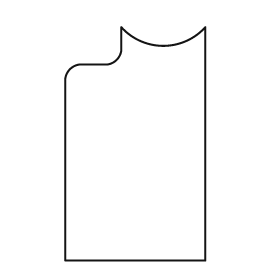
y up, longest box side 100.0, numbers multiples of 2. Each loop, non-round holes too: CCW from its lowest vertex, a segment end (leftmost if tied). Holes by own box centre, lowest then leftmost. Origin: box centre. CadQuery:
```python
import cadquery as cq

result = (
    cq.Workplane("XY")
    .moveTo(-30.0, -50.0)
    .lineTo(30.0, -50.0)
    .lineTo(30.0, 50.0)
    .threePointArc((12.0, 42.0), (-6.0, 50.0))
    .lineTo(-6.0, 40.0)
    .threePointArc((-8.0, 36.0), (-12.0, 34.0))
    .lineTo(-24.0, 34.0)
    .threePointArc((-28.0, 32.0), (-30.0, 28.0))
    .close()
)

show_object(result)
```